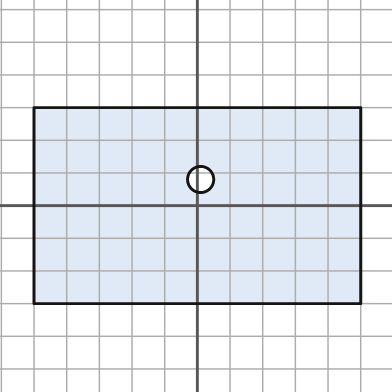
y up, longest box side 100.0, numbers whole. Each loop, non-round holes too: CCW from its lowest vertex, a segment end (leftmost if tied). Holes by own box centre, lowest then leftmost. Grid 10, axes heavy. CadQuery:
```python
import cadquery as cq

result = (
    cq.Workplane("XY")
    .moveTo(-50.0, -30.0)
    .lineTo(50.0, -30.0)
    .lineTo(50.0, 30.0)
    .lineTo(-50.0, 30.0)
    .close()
    .moveTo(1.0, 8.0)
    .circle(4.0)
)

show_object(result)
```